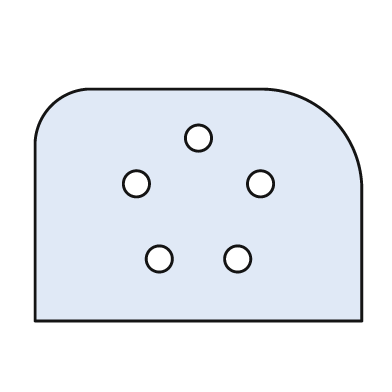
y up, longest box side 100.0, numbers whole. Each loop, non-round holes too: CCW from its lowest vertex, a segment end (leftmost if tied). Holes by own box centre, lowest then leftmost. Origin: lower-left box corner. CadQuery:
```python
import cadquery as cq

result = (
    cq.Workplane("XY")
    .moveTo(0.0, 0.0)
    .lineTo(100.0, 0.0)
    .lineTo(100.0, 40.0)
    .threePointArc((91.0, 62.0), (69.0, 71.0))
    .lineTo(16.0, 71.0)
    .threePointArc((5.0, 66.0), (0.0, 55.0))
    .close()
    .moveTo(38.0, 19.0)
    .circle(4.0)
    .moveTo(62.0, 19.0)
    .circle(4.0)
    .moveTo(31.0, 42.0)
    .circle(4.0)
    .moveTo(69.0, 42.0)
    .circle(4.0)
    .moveTo(50.0, 56.0)
    .circle(4.0)
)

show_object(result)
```